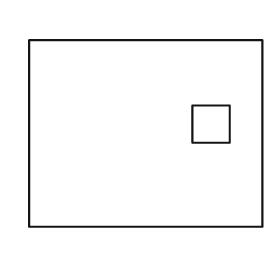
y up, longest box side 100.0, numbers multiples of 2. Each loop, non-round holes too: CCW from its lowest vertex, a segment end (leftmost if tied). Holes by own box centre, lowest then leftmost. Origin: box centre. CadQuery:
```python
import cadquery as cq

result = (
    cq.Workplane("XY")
    .moveTo(-50.0, -40.0)
    .lineTo(50.0, -40.0)
    .lineTo(50.0, 40.0)
    .lineTo(-50.0, 40.0)
    .close()
    .moveTo(20.0, -4.0)
    .lineTo(36.0, -4.0)
    .lineTo(36.0, 12.0)
    .lineTo(20.0, 12.0)
    .close()
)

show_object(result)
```